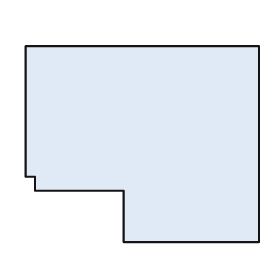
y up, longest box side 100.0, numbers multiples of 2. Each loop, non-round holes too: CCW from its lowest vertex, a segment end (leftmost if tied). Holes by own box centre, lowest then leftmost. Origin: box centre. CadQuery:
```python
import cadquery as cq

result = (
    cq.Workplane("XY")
    .moveTo(-8.0, -42.0)
    .lineTo(50.0, -42.0)
    .lineTo(50.0, 42.0)
    .lineTo(-50.0, 42.0)
    .lineTo(-50.0, -14.0)
    .lineTo(-46.0, -14.0)
    .lineTo(-46.0, -20.0)
    .lineTo(-8.0, -20.0)
    .close()
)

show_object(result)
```